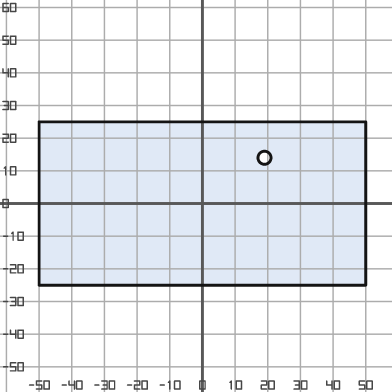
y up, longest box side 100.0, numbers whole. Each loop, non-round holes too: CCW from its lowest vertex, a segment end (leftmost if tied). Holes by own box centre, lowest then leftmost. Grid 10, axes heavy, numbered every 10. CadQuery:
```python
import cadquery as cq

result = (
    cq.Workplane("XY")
    .moveTo(-50.0, -25.0)
    .lineTo(50.0, -25.0)
    .lineTo(50.0, 25.0)
    .lineTo(-50.0, 25.0)
    .close()
    .moveTo(19.0, 14.0)
    .circle(2.0)
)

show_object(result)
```